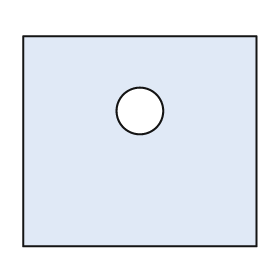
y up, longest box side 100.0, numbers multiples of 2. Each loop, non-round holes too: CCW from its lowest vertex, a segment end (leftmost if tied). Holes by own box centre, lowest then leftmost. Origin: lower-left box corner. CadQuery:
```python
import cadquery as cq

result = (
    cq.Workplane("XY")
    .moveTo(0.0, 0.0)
    .lineTo(100.0, 0.0)
    .lineTo(100.0, 90.0)
    .lineTo(0.0, 90.0)
    .close()
    .moveTo(50.0, 58.0)
    .circle(10.0)
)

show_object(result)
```